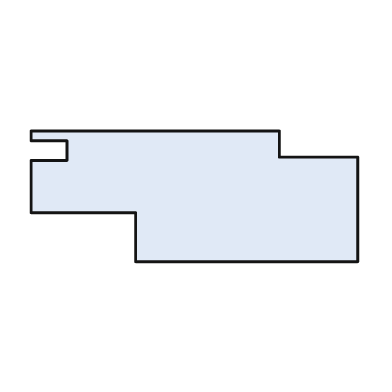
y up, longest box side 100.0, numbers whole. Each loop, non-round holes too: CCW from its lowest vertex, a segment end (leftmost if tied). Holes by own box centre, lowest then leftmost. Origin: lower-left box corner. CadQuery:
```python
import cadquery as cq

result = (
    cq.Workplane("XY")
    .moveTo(32.0, 0.0)
    .lineTo(100.0, 0.0)
    .lineTo(100.0, 32.0)
    .lineTo(76.0, 32.0)
    .lineTo(76.0, 40.0)
    .lineTo(0.0, 40.0)
    .lineTo(0.0, 37.0)
    .lineTo(11.0, 37.0)
    .lineTo(11.0, 31.0)
    .lineTo(0.0, 31.0)
    .lineTo(0.0, 15.0)
    .lineTo(32.0, 15.0)
    .close()
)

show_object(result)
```